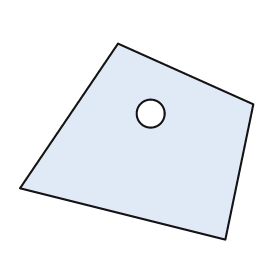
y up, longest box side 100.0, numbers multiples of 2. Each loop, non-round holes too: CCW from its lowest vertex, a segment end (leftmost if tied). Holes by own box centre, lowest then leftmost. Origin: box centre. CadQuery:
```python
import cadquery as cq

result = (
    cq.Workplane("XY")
    .moveTo(38.0, -42.0)
    .lineTo(50.0, 16.0)
    .lineTo(-8.0, 42.0)
    .lineTo(-50.0, -20.0)
    .close()
    .moveTo(6.0, 12.0)
    .circle(6.0)
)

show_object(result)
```